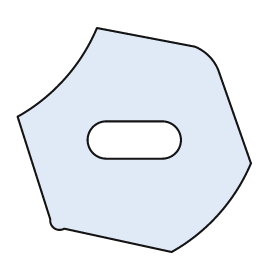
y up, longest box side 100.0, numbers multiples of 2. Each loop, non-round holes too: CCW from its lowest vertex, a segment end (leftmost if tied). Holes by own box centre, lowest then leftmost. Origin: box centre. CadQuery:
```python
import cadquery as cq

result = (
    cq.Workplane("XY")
    .moveTo(16.0, -48.0)
    .threePointArc((36.0, -32.0), (50.0, -10.0))
    .lineTo(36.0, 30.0)
    .threePointArc((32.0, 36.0), (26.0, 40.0))
    .lineTo(-16.0, 48.0)
    .threePointArc((-30.0, 26.0), (-50.0, 10.0))
    .lineTo(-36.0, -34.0)
    .threePointArc((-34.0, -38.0), (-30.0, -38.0))
    .close()
    .moveTo(-12.0, -8.0)
    .lineTo(12.0, -8.0)
    .threePointArc((20.0, 0.0), (12.0, 8.0))
    .lineTo(-12.0, 8.0)
    .threePointArc((-20.0, 0.0), (-12.0, -8.0))
    .close()
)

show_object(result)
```